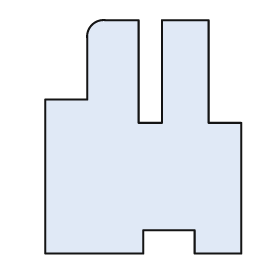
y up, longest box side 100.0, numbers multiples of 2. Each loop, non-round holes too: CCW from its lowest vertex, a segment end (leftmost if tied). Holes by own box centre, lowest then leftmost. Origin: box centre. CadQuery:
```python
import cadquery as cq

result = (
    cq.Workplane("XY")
    .moveTo(-42.0, -50.0)
    .lineTo(0.0, -50.0)
    .lineTo(0.0, -40.0)
    .lineTo(22.0, -40.0)
    .lineTo(22.0, -50.0)
    .lineTo(42.0, -50.0)
    .lineTo(42.0, 6.0)
    .lineTo(28.0, 6.0)
    .lineTo(28.0, 50.0)
    .lineTo(8.0, 50.0)
    .lineTo(8.0, 6.0)
    .lineTo(-2.0, 6.0)
    .lineTo(-2.0, 50.0)
    .lineTo(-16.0, 50.0)
    .threePointArc((-22.0, 48.0), (-24.0, 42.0))
    .lineTo(-24.0, 16.0)
    .lineTo(-42.0, 16.0)
    .close()
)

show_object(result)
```